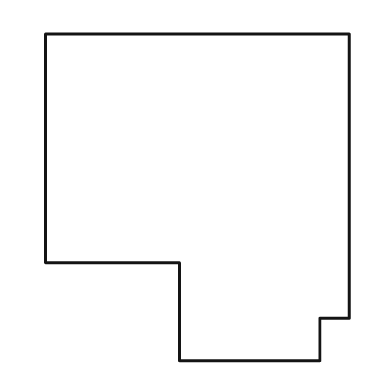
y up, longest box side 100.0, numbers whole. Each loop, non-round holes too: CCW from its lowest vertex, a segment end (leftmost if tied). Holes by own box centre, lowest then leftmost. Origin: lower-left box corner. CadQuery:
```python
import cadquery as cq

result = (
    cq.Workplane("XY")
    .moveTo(41.0, 0.0)
    .lineTo(84.0, 0.0)
    .lineTo(84.0, 13.0)
    .lineTo(93.0, 13.0)
    .lineTo(93.0, 100.0)
    .lineTo(0.0, 100.0)
    .lineTo(0.0, 30.0)
    .lineTo(41.0, 30.0)
    .close()
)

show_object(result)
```